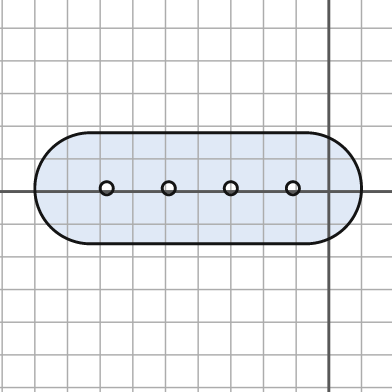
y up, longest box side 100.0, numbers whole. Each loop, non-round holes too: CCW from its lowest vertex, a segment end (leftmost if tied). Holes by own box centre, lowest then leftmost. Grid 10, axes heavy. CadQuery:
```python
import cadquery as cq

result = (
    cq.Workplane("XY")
    .moveTo(-73.0, -16.0)
    .lineTo(-7.0, -16.0)
    .threePointArc((10.0, 1.0), (-7.0, 18.0))
    .lineTo(-73.0, 18.0)
    .threePointArc((-90.0, 1.0), (-73.0, -16.0))
    .close()
    .moveTo(-68.0, 1.0)
    .circle(2.0)
    .moveTo(-49.0, 1.0)
    .circle(2.0)
    .moveTo(-30.0, 1.0)
    .circle(2.0)
    .moveTo(-11.0, 1.0)
    .circle(2.0)
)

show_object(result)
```